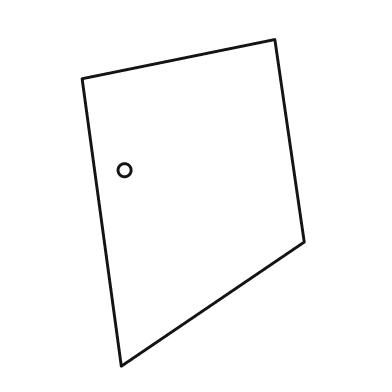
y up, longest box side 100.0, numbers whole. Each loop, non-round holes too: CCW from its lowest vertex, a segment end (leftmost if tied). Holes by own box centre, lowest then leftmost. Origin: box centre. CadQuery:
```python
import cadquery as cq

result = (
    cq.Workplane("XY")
    .moveTo(-22.0, -50.0)
    .lineTo(34.0, -12.0)
    .lineTo(25.0, 50.0)
    .lineTo(-34.0, 38.0)
    .close()
    .moveTo(-21.0, 10.0)
    .circle(2.0)
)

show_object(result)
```